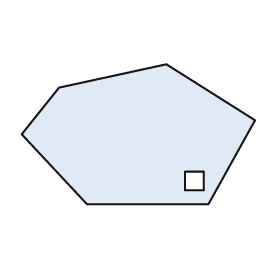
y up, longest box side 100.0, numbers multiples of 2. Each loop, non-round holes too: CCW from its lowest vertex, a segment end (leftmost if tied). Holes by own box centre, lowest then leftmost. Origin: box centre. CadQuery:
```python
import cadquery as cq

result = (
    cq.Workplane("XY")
    .moveTo(-22.0, -30.0)
    .lineTo(30.0, -30.0)
    .lineTo(50.0, 6.0)
    .lineTo(12.0, 30.0)
    .lineTo(-34.0, 20.0)
    .lineTo(-50.0, 0.0)
    .close()
    .moveTo(20.0, -24.0)
    .lineTo(28.0, -24.0)
    .lineTo(28.0, -16.0)
    .lineTo(20.0, -16.0)
    .close()
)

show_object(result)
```